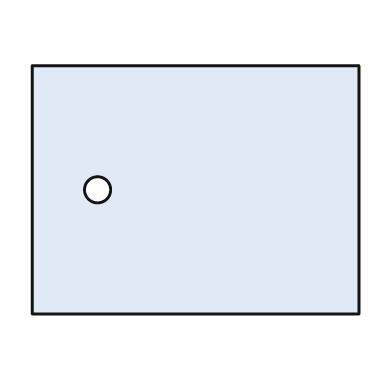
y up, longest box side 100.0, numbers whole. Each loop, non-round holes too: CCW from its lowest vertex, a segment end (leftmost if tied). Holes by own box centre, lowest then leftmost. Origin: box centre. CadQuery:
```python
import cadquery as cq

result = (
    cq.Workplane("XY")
    .moveTo(-50.0, -38.0)
    .lineTo(50.0, -38.0)
    .lineTo(50.0, 38.0)
    .lineTo(-50.0, 38.0)
    .close()
    .moveTo(-30.0, 0.0)
    .circle(4.0)
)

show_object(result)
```